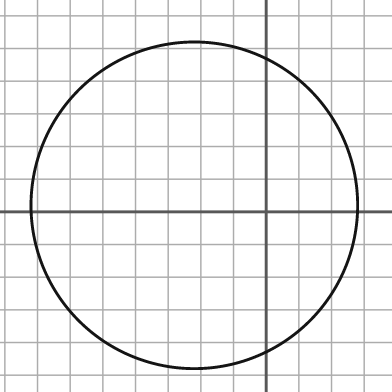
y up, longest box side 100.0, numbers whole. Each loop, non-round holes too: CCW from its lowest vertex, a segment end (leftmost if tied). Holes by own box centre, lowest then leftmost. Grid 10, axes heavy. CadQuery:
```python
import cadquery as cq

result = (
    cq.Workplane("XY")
    .moveTo(-22.0, 2.0)
    .circle(50.0)
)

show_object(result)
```